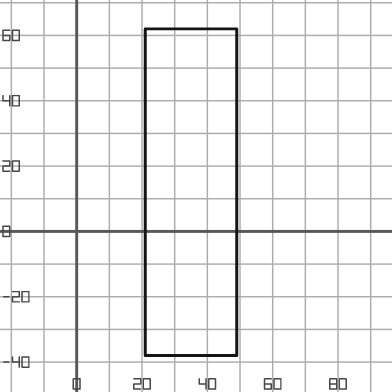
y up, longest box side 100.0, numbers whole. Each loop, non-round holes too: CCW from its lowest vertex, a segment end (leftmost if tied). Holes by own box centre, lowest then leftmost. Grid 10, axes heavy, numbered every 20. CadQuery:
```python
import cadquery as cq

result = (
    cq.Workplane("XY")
    .moveTo(21.0, -38.0)
    .lineTo(49.0, -38.0)
    .lineTo(49.0, 62.0)
    .lineTo(21.0, 62.0)
    .close()
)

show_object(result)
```